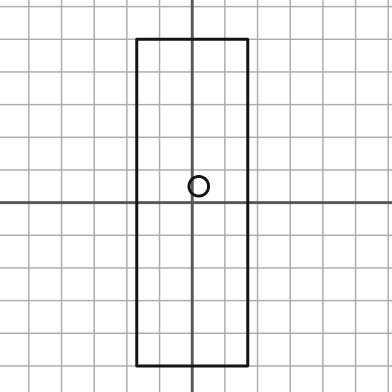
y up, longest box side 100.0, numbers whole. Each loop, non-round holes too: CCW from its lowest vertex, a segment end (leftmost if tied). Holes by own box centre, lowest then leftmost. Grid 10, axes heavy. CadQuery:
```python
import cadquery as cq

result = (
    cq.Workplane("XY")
    .moveTo(-17.0, -50.0)
    .lineTo(17.0, -50.0)
    .lineTo(17.0, 50.0)
    .lineTo(-17.0, 50.0)
    .close()
    .moveTo(2.0, 5.0)
    .circle(3.0)
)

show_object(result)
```